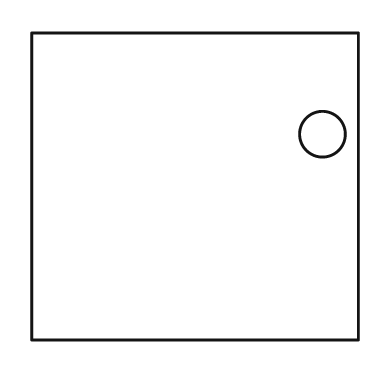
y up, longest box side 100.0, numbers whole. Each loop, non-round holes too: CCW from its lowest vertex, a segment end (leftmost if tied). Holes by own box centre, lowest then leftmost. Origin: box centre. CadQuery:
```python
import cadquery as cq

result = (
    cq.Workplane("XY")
    .moveTo(-50.0, -47.0)
    .lineTo(50.0, -47.0)
    .lineTo(50.0, 47.0)
    .lineTo(-50.0, 47.0)
    .close()
    .moveTo(39.0, 16.0)
    .circle(7.0)
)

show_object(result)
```